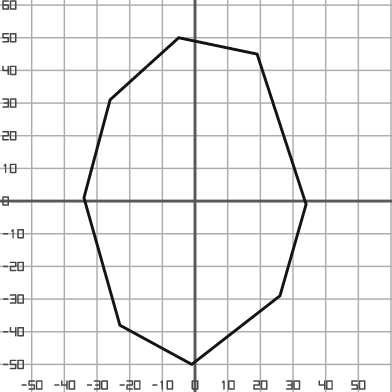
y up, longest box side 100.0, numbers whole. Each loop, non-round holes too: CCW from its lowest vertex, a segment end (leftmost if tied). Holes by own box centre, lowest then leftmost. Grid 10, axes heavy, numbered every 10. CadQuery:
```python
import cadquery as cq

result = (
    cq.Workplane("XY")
    .moveTo(-1.0, -50.0)
    .lineTo(26.0, -29.0)
    .lineTo(34.0, -1.0)
    .lineTo(19.0, 45.0)
    .lineTo(-5.0, 50.0)
    .lineTo(-26.0, 31.0)
    .lineTo(-34.0, 1.0)
    .lineTo(-23.0, -38.0)
    .close()
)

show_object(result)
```